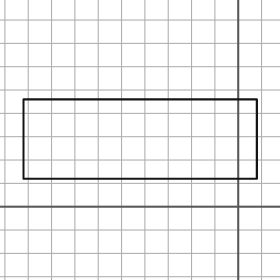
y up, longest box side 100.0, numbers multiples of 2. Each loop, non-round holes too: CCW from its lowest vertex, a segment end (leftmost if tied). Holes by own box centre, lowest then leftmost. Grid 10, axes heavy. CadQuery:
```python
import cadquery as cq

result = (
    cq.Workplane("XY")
    .moveTo(-92.0, 12.0)
    .lineTo(8.0, 12.0)
    .lineTo(8.0, 46.0)
    .lineTo(-92.0, 46.0)
    .close()
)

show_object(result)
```